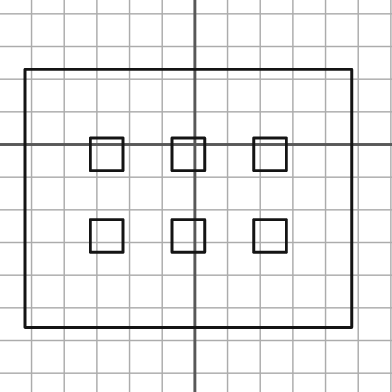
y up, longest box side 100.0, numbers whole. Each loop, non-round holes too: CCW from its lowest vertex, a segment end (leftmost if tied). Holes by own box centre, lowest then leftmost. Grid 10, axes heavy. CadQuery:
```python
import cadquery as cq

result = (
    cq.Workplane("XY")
    .moveTo(-52.0, -56.0)
    .lineTo(48.0, -56.0)
    .lineTo(48.0, 23.0)
    .lineTo(-52.0, 23.0)
    .close()
    .moveTo(-32.0, -33.0)
    .lineTo(-22.0, -33.0)
    .lineTo(-22.0, -23.0)
    .lineTo(-32.0, -23.0)
    .close()
    .moveTo(-7.0, -33.0)
    .lineTo(3.0, -33.0)
    .lineTo(3.0, -23.0)
    .lineTo(-7.0, -23.0)
    .close()
    .moveTo(18.0, -33.0)
    .lineTo(28.0, -33.0)
    .lineTo(28.0, -23.0)
    .lineTo(18.0, -23.0)
    .close()
    .moveTo(-32.0, -8.0)
    .lineTo(-22.0, -8.0)
    .lineTo(-22.0, 2.0)
    .lineTo(-32.0, 2.0)
    .close()
    .moveTo(-7.0, -8.0)
    .lineTo(3.0, -8.0)
    .lineTo(3.0, 2.0)
    .lineTo(-7.0, 2.0)
    .close()
    .moveTo(18.0, -8.0)
    .lineTo(28.0, -8.0)
    .lineTo(28.0, 2.0)
    .lineTo(18.0, 2.0)
    .close()
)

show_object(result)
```